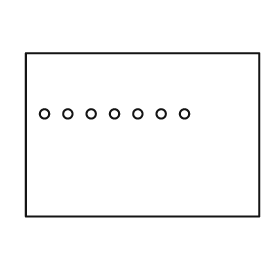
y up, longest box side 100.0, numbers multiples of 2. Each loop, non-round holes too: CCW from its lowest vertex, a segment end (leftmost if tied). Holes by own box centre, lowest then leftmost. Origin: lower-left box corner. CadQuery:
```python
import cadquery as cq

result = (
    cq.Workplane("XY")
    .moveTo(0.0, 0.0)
    .lineTo(100.0, 0.0)
    .lineTo(100.0, 70.0)
    .lineTo(0.0, 70.0)
    .close()
    .moveTo(8.0, 44.0)
    .circle(2.0)
    .moveTo(18.0, 44.0)
    .circle(2.0)
    .moveTo(28.0, 44.0)
    .circle(2.0)
    .moveTo(38.0, 44.0)
    .circle(2.0)
    .moveTo(48.0, 44.0)
    .circle(2.0)
    .moveTo(58.0, 44.0)
    .circle(2.0)
    .moveTo(68.0, 44.0)
    .circle(2.0)
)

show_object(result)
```